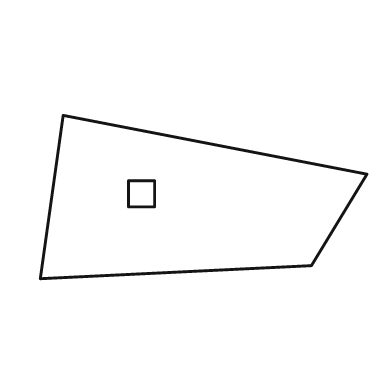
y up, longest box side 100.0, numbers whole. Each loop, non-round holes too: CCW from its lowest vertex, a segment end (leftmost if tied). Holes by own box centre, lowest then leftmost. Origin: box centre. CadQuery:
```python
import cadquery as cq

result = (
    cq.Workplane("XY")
    .moveTo(-50.0, -25.0)
    .lineTo(33.0, -21.0)
    .lineTo(50.0, 7.0)
    .lineTo(-43.0, 25.0)
    .close()
    .moveTo(-23.0, -3.0)
    .lineTo(-15.0, -3.0)
    .lineTo(-15.0, 5.0)
    .lineTo(-23.0, 5.0)
    .close()
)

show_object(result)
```